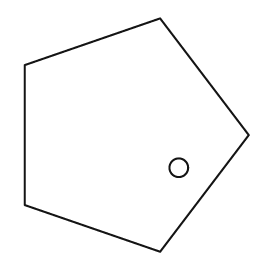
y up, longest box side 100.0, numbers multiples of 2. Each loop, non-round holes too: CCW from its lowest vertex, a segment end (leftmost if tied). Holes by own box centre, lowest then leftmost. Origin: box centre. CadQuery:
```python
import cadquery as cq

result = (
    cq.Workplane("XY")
    .moveTo(10.0, -50.0)
    .lineTo(48.0, 0.0)
    .lineTo(10.0, 50.0)
    .lineTo(-48.0, 30.0)
    .lineTo(-48.0, -30.0)
    .close()
    .moveTo(18.0, -14.0)
    .circle(4.0)
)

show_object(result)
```